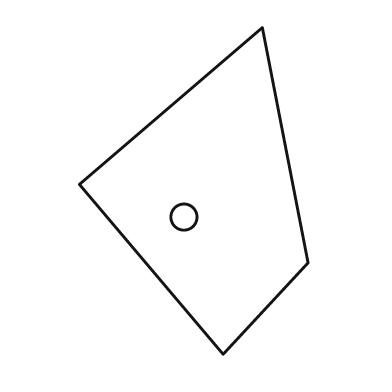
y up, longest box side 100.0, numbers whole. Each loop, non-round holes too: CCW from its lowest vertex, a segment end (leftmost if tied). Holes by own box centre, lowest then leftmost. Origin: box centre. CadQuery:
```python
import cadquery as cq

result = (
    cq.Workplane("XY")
    .moveTo(9.0, -50.0)
    .lineTo(35.0, -22.0)
    .lineTo(21.0, 50.0)
    .lineTo(-35.0, 2.0)
    .close()
    .moveTo(-3.0, -8.0)
    .circle(4.0)
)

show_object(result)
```